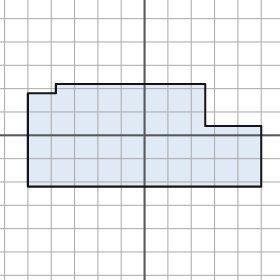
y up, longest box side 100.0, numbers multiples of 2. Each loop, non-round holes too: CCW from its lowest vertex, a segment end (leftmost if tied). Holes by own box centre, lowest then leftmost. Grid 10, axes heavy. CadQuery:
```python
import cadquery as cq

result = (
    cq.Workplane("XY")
    .moveTo(-50.0, -22.0)
    .lineTo(50.0, -22.0)
    .lineTo(50.0, 4.0)
    .lineTo(26.0, 4.0)
    .lineTo(26.0, 22.0)
    .lineTo(-38.0, 22.0)
    .lineTo(-38.0, 18.0)
    .lineTo(-50.0, 18.0)
    .close()
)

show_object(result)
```